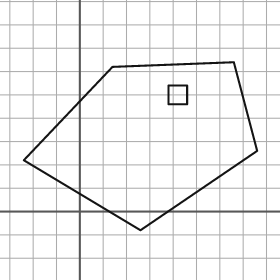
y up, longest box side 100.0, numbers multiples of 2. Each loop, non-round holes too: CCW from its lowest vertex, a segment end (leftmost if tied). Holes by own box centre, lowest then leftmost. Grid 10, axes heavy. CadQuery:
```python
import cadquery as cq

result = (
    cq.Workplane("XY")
    .moveTo(26.0, -8.0)
    .lineTo(76.0, 26.0)
    .lineTo(66.0, 64.0)
    .lineTo(14.0, 62.0)
    .lineTo(-24.0, 22.0)
    .close()
    .moveTo(38.0, 46.0)
    .lineTo(46.0, 46.0)
    .lineTo(46.0, 54.0)
    .lineTo(38.0, 54.0)
    .close()
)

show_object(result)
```